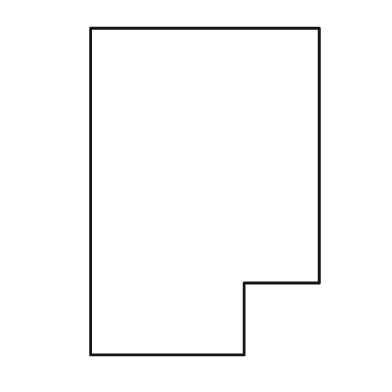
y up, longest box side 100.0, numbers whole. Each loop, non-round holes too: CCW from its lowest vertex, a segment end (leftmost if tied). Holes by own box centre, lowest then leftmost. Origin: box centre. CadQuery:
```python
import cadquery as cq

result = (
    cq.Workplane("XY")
    .moveTo(-35.0, -50.0)
    .lineTo(12.0, -50.0)
    .lineTo(12.0, -28.0)
    .lineTo(35.0, -28.0)
    .lineTo(35.0, 50.0)
    .lineTo(-35.0, 50.0)
    .close()
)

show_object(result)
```